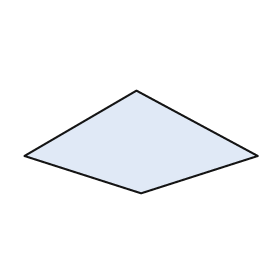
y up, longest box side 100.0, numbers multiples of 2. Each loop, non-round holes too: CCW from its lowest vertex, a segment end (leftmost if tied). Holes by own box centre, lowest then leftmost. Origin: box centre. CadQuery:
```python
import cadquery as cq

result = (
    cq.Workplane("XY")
    .moveTo(0.0, -22.0)
    .lineTo(50.0, -6.0)
    .lineTo(-2.0, 22.0)
    .lineTo(-50.0, -6.0)
    .close()
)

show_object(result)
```